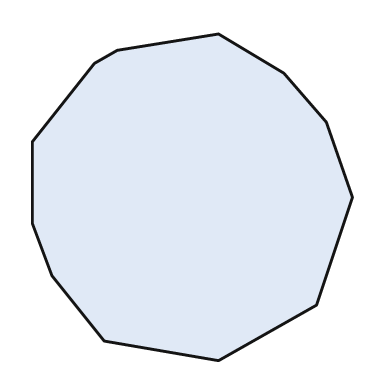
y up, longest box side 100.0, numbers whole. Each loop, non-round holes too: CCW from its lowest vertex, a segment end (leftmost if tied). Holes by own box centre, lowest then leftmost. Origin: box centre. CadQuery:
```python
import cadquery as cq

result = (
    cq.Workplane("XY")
    .moveTo(8.0, -50.0)
    .lineTo(38.0, -33.0)
    .lineTo(49.0, 0.0)
    .lineTo(41.0, 23.0)
    .lineTo(28.0, 38.0)
    .lineTo(8.0, 50.0)
    .lineTo(-23.0, 45.0)
    .lineTo(-30.0, 41.0)
    .lineTo(-49.0, 17.0)
    .lineTo(-49.0, -8.0)
    .lineTo(-43.0, -24.0)
    .lineTo(-27.0, -44.0)
    .close()
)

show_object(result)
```